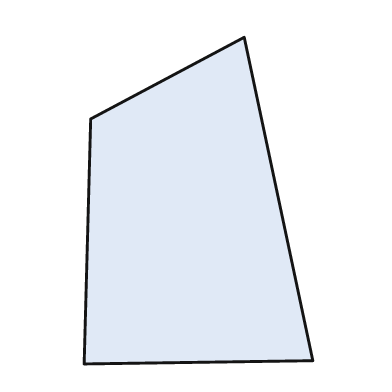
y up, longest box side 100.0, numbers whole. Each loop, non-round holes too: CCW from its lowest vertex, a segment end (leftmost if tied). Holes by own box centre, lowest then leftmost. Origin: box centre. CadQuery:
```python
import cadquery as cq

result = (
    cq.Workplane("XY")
    .moveTo(-35.0, -50.0)
    .lineTo(35.0, -49.0)
    .lineTo(14.0, 50.0)
    .lineTo(-33.0, 25.0)
    .close()
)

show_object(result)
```